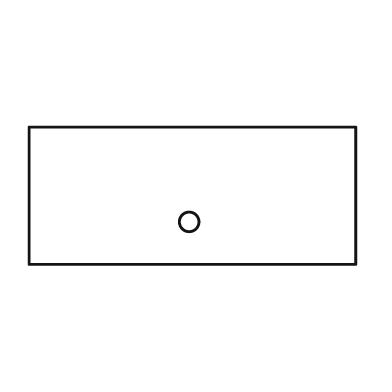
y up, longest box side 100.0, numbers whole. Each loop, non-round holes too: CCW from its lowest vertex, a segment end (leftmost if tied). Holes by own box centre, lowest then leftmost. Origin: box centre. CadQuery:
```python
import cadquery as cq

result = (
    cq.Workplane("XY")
    .moveTo(-50.0, -21.0)
    .lineTo(50.0, -21.0)
    .lineTo(50.0, 21.0)
    .lineTo(-50.0, 21.0)
    .close()
    .moveTo(-1.0, -8.0)
    .circle(3.0)
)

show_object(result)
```